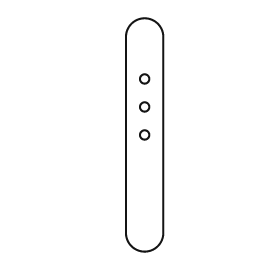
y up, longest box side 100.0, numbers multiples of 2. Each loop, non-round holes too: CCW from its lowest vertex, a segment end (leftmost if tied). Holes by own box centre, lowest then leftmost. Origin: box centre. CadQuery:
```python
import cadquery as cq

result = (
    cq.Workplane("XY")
    .moveTo(-8.0, -42.0)
    .threePointArc((0.0, -50.0), (8.0, -42.0))
    .lineTo(8.0, 42.0)
    .threePointArc((0.0, 50.0), (-8.0, 42.0))
    .close()
    .moveTo(0.0, 0.0)
    .circle(2.0)
    .moveTo(0.0, 12.0)
    .circle(2.0)
    .moveTo(0.0, 24.0)
    .circle(2.0)
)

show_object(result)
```